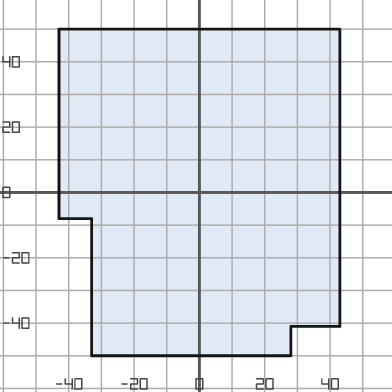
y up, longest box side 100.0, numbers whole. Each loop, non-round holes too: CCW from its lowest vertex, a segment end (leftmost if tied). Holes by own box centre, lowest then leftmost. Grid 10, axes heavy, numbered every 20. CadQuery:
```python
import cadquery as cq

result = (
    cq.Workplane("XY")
    .moveTo(-33.0, -50.0)
    .lineTo(28.0, -50.0)
    .lineTo(28.0, -41.0)
    .lineTo(43.0, -41.0)
    .lineTo(43.0, 50.0)
    .lineTo(-43.0, 50.0)
    .lineTo(-43.0, -8.0)
    .lineTo(-33.0, -8.0)
    .close()
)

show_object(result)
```